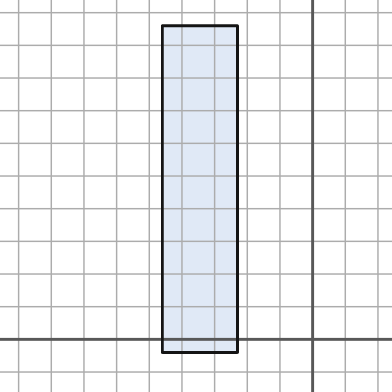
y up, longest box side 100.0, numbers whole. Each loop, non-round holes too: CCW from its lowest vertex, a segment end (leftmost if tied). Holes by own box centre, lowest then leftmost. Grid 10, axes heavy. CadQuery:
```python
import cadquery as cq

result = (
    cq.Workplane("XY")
    .moveTo(-46.0, -4.0)
    .lineTo(-23.0, -4.0)
    .lineTo(-23.0, 96.0)
    .lineTo(-46.0, 96.0)
    .close()
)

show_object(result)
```